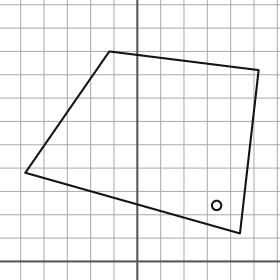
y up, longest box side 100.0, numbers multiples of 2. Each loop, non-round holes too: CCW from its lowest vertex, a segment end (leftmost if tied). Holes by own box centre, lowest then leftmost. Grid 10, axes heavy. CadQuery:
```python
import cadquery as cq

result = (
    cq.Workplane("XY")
    .moveTo(44.0, 12.0)
    .lineTo(52.0, 82.0)
    .lineTo(-12.0, 90.0)
    .lineTo(-48.0, 38.0)
    .close()
    .moveTo(34.0, 24.0)
    .circle(2.0)
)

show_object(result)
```